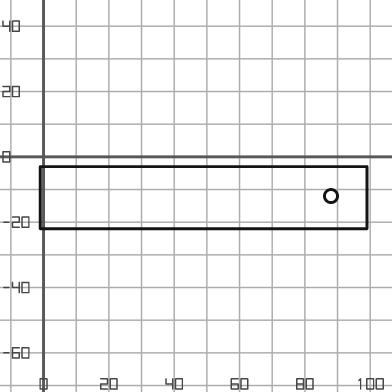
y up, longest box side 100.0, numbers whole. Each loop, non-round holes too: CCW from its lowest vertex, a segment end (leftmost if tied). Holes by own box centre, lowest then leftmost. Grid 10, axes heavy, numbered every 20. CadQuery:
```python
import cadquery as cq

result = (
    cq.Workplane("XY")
    .moveTo(-1.0, -22.0)
    .lineTo(99.0, -22.0)
    .lineTo(99.0, -3.0)
    .lineTo(-1.0, -3.0)
    .close()
    .moveTo(88.0, -12.0)
    .circle(2.0)
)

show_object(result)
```